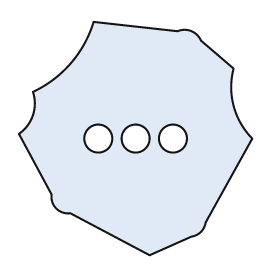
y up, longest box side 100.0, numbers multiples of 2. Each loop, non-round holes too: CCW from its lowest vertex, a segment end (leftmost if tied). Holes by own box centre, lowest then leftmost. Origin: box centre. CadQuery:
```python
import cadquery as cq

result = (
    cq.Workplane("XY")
    .moveTo(6.0, -50.0)
    .lineTo(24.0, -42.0)
    .threePointArc((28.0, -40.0), (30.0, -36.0))
    .lineTo(50.0, 0.0)
    .threePointArc((42.0, 14.0), (42.0, 30.0))
    .lineTo(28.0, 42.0)
    .threePointArc((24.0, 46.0), (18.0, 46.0))
    .lineTo(-18.0, 50.0)
    .threePointArc((-28.0, 32.0), (-44.0, 20.0))
    .threePointArc((-44.0, 10.0), (-50.0, 2.0))
    .lineTo(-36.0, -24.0)
    .threePointArc((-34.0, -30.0), (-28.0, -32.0))
    .close()
    .moveTo(-16.0, 0.0)
    .circle(6.0)
    .moveTo(0.0, 0.0)
    .circle(6.0)
    .moveTo(16.0, 0.0)
    .circle(6.0)
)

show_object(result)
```